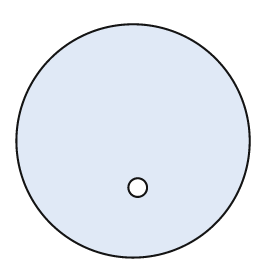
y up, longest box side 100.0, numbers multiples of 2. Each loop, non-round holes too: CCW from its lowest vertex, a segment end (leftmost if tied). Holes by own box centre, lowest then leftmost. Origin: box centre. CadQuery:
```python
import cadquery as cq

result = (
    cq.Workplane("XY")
    .moveTo(0.0, 0.0)
    .circle(50.0)
    .moveTo(2.0, -20.0)
    .circle(4.0)
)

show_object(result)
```